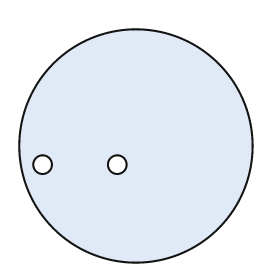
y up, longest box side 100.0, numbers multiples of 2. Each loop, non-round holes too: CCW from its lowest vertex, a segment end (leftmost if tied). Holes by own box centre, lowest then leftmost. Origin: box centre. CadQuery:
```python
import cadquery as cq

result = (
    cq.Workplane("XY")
    .moveTo(0.0, 0.0)
    .circle(50.0)
    .moveTo(-40.0, -8.0)
    .circle(4.0)
    .moveTo(-8.0, -8.0)
    .circle(4.0)
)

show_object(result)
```